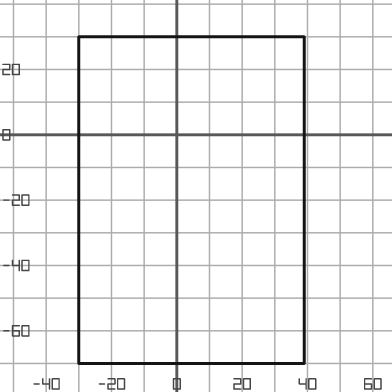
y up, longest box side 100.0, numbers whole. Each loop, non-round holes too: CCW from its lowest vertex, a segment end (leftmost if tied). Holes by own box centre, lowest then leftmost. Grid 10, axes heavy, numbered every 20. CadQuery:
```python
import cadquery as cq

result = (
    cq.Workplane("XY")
    .moveTo(-30.0, -70.0)
    .lineTo(39.0, -70.0)
    .lineTo(39.0, 30.0)
    .lineTo(-30.0, 30.0)
    .close()
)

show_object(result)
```